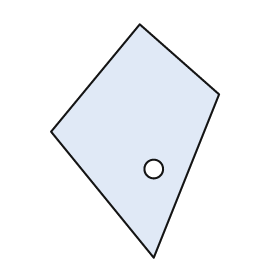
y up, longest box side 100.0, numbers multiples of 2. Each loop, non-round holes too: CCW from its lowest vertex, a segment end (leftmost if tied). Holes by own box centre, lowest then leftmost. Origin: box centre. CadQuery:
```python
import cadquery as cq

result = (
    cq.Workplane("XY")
    .moveTo(8.0, -50.0)
    .lineTo(36.0, 20.0)
    .lineTo(2.0, 50.0)
    .lineTo(-36.0, 4.0)
    .close()
    .moveTo(8.0, -12.0)
    .circle(4.0)
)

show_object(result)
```